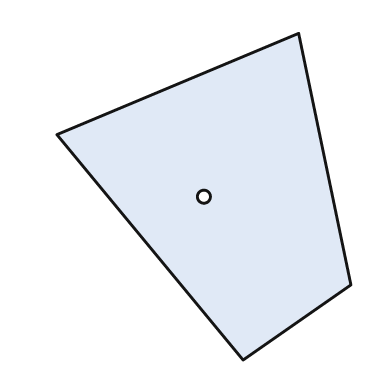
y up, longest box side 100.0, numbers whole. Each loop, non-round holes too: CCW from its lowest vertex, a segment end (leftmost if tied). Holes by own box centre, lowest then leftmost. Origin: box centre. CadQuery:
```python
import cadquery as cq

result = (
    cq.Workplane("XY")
    .moveTo(12.0, -50.0)
    .lineTo(45.0, -27.0)
    .lineTo(29.0, 50.0)
    .lineTo(-45.0, 19.0)
    .close()
    .moveTo(0.0, 0.0)
    .circle(2.0)
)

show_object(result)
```